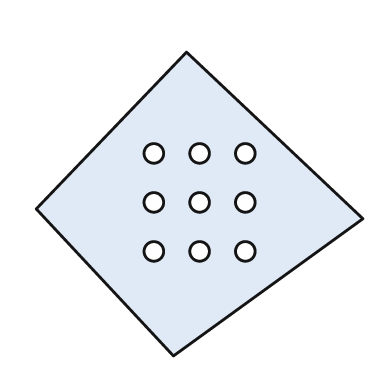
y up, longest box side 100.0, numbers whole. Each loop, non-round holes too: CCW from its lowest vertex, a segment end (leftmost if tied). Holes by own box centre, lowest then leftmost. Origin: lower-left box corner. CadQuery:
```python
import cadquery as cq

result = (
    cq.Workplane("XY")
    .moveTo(42.0, 0.0)
    .lineTo(100.0, 42.0)
    .lineTo(46.0, 93.0)
    .lineTo(0.0, 45.0)
    .close()
    .moveTo(36.0, 32.0)
    .circle(3.0)
    .moveTo(50.0, 32.0)
    .circle(3.0)
    .moveTo(64.0, 32.0)
    .circle(3.0)
    .moveTo(36.0, 47.0)
    .circle(3.0)
    .moveTo(50.0, 47.0)
    .circle(3.0)
    .moveTo(64.0, 47.0)
    .circle(3.0)
    .moveTo(36.0, 62.0)
    .circle(3.0)
    .moveTo(50.0, 62.0)
    .circle(3.0)
    .moveTo(64.0, 62.0)
    .circle(3.0)
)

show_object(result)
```